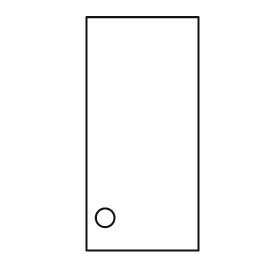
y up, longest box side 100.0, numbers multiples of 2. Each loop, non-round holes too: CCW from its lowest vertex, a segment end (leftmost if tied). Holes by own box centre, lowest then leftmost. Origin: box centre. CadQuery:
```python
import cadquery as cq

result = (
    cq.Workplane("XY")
    .moveTo(-24.0, -50.0)
    .lineTo(24.0, -50.0)
    .lineTo(24.0, 50.0)
    .lineTo(-24.0, 50.0)
    .close()
    .moveTo(-16.0, -36.0)
    .circle(4.0)
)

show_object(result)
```